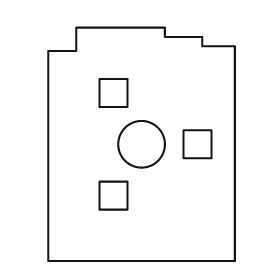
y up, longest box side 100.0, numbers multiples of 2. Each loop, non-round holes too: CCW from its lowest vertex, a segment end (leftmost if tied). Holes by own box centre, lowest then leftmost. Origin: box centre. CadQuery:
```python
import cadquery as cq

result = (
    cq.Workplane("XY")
    .moveTo(-40.0, -50.0)
    .lineTo(40.0, -50.0)
    .lineTo(40.0, 42.0)
    .lineTo(26.0, 42.0)
    .lineTo(26.0, 46.0)
    .lineTo(10.0, 46.0)
    .lineTo(10.0, 50.0)
    .lineTo(-28.0, 50.0)
    .lineTo(-28.0, 40.0)
    .lineTo(-40.0, 40.0)
    .close()
    .moveTo(-18.0, -28.0)
    .lineTo(-6.0, -28.0)
    .lineTo(-6.0, -16.0)
    .lineTo(-18.0, -16.0)
    .close()
    .moveTo(0.0, 0.0)
    .circle(10.0)
    .moveTo(18.0, -6.0)
    .lineTo(30.0, -6.0)
    .lineTo(30.0, 6.0)
    .lineTo(18.0, 6.0)
    .close()
    .moveTo(-18.0, 16.0)
    .lineTo(-6.0, 16.0)
    .lineTo(-6.0, 28.0)
    .lineTo(-18.0, 28.0)
    .close()
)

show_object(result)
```